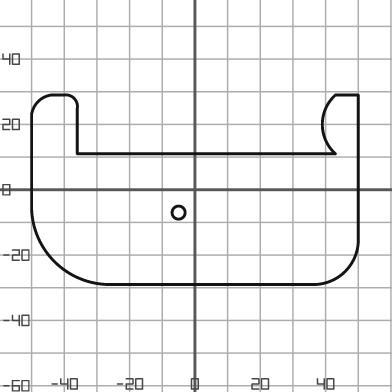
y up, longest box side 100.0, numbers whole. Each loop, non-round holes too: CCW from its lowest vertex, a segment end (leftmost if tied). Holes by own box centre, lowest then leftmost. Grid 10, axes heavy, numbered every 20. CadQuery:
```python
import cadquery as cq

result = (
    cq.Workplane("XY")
    .moveTo(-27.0, -29.0)
    .lineTo(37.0, -29.0)
    .threePointArc((46.0, -25.0), (50.0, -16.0))
    .lineTo(50.0, 29.0)
    .lineTo(43.0, 29.0)
    .threePointArc((39.0, 20.0), (43.0, 11.0))
    .lineTo(-36.0, 11.0)
    .lineTo(-36.0, 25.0)
    .threePointArc((-37.0, 28.0), (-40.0, 29.0))
    .lineTo(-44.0, 29.0)
    .threePointArc((-48.0, 27.0), (-50.0, 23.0))
    .lineTo(-50.0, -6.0)
    .threePointArc((-43.0, -22.0), (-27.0, -29.0))
    .close()
    .moveTo(-5.0, -7.0)
    .circle(2.0)
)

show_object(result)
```